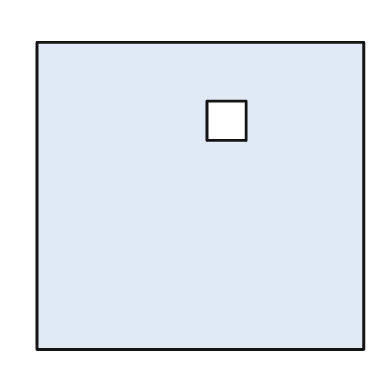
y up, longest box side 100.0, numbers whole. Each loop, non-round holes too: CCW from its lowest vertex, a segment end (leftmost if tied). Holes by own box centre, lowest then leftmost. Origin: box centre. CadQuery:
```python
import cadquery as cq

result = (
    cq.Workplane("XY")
    .moveTo(-50.0, -47.0)
    .lineTo(50.0, -47.0)
    .lineTo(50.0, 47.0)
    .lineTo(-50.0, 47.0)
    .close()
    .moveTo(2.0, 17.0)
    .lineTo(14.0, 17.0)
    .lineTo(14.0, 29.0)
    .lineTo(2.0, 29.0)
    .close()
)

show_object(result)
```